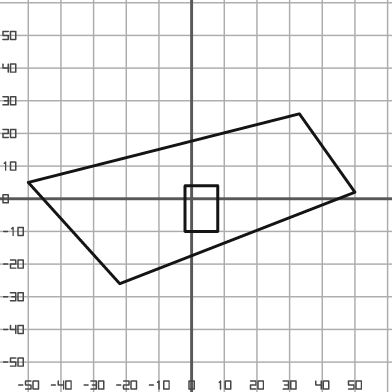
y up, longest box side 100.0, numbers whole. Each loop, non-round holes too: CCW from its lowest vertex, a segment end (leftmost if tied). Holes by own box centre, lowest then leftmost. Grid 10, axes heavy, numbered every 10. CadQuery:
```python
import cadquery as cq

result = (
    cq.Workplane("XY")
    .moveTo(-22.0, -26.0)
    .lineTo(50.0, 2.0)
    .lineTo(33.0, 26.0)
    .lineTo(-50.0, 5.0)
    .close()
    .moveTo(-2.0, -10.0)
    .lineTo(8.0, -10.0)
    .lineTo(8.0, 4.0)
    .lineTo(-2.0, 4.0)
    .close()
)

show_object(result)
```